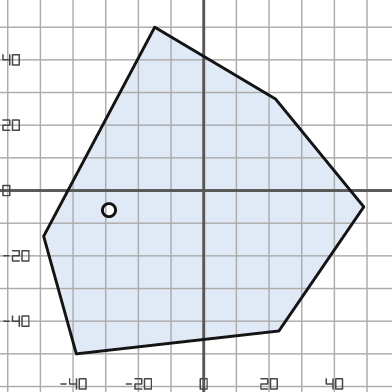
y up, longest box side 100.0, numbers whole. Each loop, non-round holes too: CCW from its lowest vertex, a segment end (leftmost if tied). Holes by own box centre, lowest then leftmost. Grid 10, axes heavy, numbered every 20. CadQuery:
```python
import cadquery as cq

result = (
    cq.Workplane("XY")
    .moveTo(-39.0, -50.0)
    .lineTo(23.0, -43.0)
    .lineTo(49.0, -5.0)
    .lineTo(22.0, 28.0)
    .lineTo(-15.0, 50.0)
    .lineTo(-49.0, -14.0)
    .close()
    .moveTo(-29.0, -6.0)
    .circle(2.0)
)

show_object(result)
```